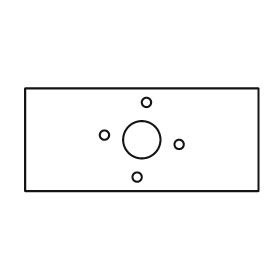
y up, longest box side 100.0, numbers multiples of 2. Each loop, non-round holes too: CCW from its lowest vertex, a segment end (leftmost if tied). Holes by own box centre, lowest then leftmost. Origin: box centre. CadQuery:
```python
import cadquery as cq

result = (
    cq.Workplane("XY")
    .moveTo(-50.0, -22.0)
    .lineTo(50.0, -22.0)
    .lineTo(50.0, 22.0)
    .lineTo(-50.0, 22.0)
    .close()
    .moveTo(-2.0, -16.0)
    .circle(2.0)
    .moveTo(16.0, -2.0)
    .circle(2.0)
    .moveTo(0.0, 0.0)
    .circle(8.0)
    .moveTo(-16.0, 2.0)
    .circle(2.0)
    .moveTo(2.0, 16.0)
    .circle(2.0)
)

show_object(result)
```